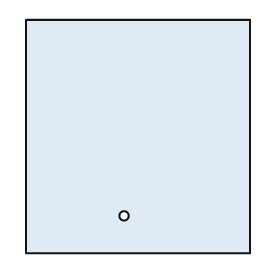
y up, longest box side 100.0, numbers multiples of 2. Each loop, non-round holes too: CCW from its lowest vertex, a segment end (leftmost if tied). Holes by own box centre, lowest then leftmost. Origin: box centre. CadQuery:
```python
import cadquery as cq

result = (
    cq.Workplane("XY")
    .moveTo(-48.0, -50.0)
    .lineTo(48.0, -50.0)
    .lineTo(48.0, 50.0)
    .lineTo(-48.0, 50.0)
    .close()
    .moveTo(-6.0, -34.0)
    .circle(2.0)
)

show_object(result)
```